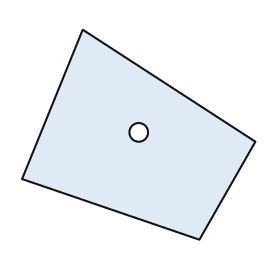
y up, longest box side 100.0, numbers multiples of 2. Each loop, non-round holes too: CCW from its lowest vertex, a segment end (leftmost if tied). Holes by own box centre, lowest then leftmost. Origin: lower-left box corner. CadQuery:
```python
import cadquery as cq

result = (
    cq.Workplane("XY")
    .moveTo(76.0, 0.0)
    .lineTo(100.0, 42.0)
    .lineTo(26.0, 90.0)
    .lineTo(0.0, 26.0)
    .close()
    .moveTo(50.0, 46.0)
    .circle(4.0)
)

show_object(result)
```